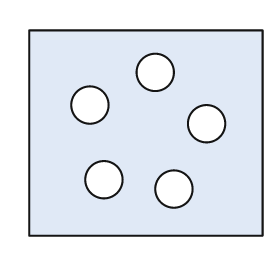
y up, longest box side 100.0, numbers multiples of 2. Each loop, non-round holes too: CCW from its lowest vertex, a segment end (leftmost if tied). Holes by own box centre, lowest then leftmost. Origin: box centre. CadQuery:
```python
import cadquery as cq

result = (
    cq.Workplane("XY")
    .moveTo(-50.0, -44.0)
    .lineTo(50.0, -44.0)
    .lineTo(50.0, 44.0)
    .lineTo(-50.0, 44.0)
    .close()
    .moveTo(12.0, -24.0)
    .circle(8.0)
    .moveTo(-18.0, -20.0)
    .circle(8.0)
    .moveTo(26.0, 4.0)
    .circle(8.0)
    .moveTo(-24.0, 12.0)
    .circle(8.0)
    .moveTo(4.0, 26.0)
    .circle(8.0)
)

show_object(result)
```